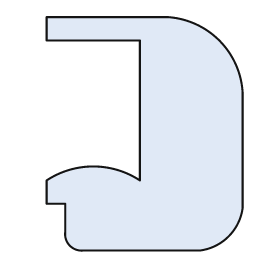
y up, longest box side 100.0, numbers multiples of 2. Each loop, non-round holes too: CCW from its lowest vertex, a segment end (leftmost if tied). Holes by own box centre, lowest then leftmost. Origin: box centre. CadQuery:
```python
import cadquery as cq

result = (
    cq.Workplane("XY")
    .moveTo(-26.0, -50.0)
    .lineTo(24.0, -50.0)
    .threePointArc((36.0, -44.0), (42.0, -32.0))
    .lineTo(42.0, 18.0)
    .threePointArc((32.0, 40.0), (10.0, 50.0))
    .lineTo(-42.0, 50.0)
    .lineTo(-42.0, 40.0)
    .lineTo(-2.0, 40.0)
    .lineTo(-2.0, -20.0)
    .threePointArc((-22.0, -14.0), (-42.0, -20.0))
    .lineTo(-42.0, -30.0)
    .lineTo(-34.0, -30.0)
    .lineTo(-34.0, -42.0)
    .threePointArc((-32.0, -48.0), (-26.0, -50.0))
    .close()
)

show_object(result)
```